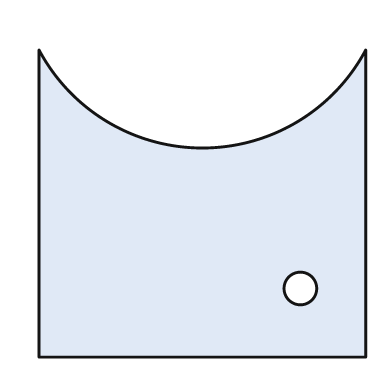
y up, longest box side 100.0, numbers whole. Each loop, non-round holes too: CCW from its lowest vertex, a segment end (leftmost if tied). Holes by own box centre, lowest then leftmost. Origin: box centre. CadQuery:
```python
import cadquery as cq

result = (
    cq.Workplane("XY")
    .moveTo(-50.0, -47.0)
    .lineTo(50.0, -47.0)
    .lineTo(50.0, 47.0)
    .threePointArc((0.0, 17.0), (-50.0, 47.0))
    .close()
    .moveTo(30.0, -26.0)
    .circle(5.0)
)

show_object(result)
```